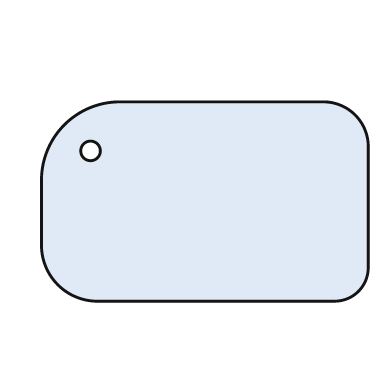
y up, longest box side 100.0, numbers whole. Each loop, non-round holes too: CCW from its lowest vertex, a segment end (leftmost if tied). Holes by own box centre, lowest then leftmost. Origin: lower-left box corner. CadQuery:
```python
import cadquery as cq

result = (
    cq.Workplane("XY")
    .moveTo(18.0, 0.0)
    .lineTo(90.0, 0.0)
    .threePointArc((97.0, 3.0), (100.0, 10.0))
    .lineTo(100.0, 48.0)
    .threePointArc((96.0, 57.0), (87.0, 61.0))
    .lineTo(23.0, 61.0)
    .threePointArc((7.0, 54.0), (0.0, 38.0))
    .lineTo(0.0, 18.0)
    .threePointArc((5.0, 5.0), (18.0, 0.0))
    .close()
    .moveTo(15.0, 46.0)
    .circle(3.0)
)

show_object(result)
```